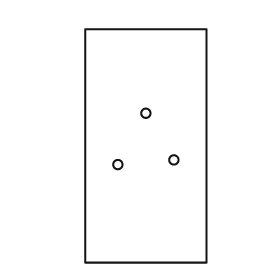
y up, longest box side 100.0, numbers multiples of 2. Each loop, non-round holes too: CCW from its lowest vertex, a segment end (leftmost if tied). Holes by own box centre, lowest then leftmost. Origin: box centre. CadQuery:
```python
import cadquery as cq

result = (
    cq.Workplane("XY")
    .moveTo(-26.0, -50.0)
    .lineTo(26.0, -50.0)
    .lineTo(26.0, 50.0)
    .lineTo(-26.0, 50.0)
    .close()
    .moveTo(-12.0, -8.0)
    .circle(2.0)
    .moveTo(12.0, -6.0)
    .circle(2.0)
    .moveTo(0.0, 14.0)
    .circle(2.0)
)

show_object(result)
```